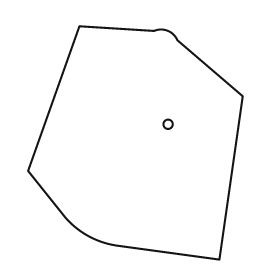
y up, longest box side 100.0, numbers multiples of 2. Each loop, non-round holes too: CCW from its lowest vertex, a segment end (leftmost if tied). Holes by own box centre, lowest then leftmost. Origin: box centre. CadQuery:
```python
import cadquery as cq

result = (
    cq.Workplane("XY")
    .moveTo(36.0, -50.0)
    .lineTo(46.0, 20.0)
    .lineTo(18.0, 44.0)
    .threePointArc((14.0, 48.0), (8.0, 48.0))
    .lineTo(-24.0, 50.0)
    .lineTo(-46.0, -12.0)
    .lineTo(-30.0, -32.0)
    .threePointArc((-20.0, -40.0), (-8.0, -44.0))
    .close()
    .moveTo(14.0, 8.0)
    .circle(2.0)
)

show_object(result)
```